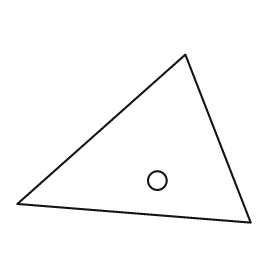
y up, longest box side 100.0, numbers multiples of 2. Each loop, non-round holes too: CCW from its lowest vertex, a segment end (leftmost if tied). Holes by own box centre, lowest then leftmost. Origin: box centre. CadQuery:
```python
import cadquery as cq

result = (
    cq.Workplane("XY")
    .moveTo(50.0, -36.0)
    .lineTo(22.0, 36.0)
    .lineTo(-50.0, -28.0)
    .close()
    .moveTo(10.0, -18.0)
    .circle(4.0)
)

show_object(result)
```